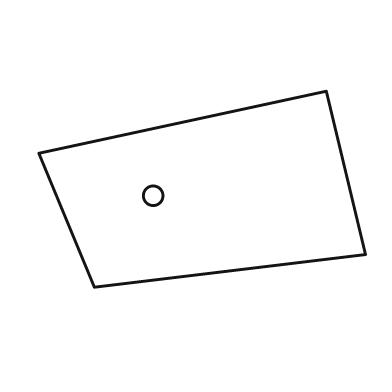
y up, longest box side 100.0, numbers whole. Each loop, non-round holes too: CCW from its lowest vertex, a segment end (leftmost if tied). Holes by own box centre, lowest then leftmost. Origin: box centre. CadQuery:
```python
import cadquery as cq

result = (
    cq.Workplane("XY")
    .moveTo(-33.0, -30.0)
    .lineTo(50.0, -20.0)
    .lineTo(38.0, 30.0)
    .lineTo(-50.0, 11.0)
    .close()
    .moveTo(-15.0, -2.0)
    .circle(3.0)
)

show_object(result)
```